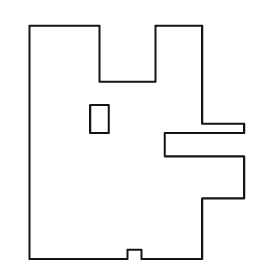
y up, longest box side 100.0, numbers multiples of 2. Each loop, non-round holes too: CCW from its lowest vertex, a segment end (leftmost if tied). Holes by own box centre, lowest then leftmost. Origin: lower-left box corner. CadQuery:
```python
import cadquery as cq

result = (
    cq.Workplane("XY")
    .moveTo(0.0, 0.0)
    .lineTo(42.0, 0.0)
    .lineTo(42.0, 4.0)
    .lineTo(48.0, 4.0)
    .lineTo(48.0, 0.0)
    .lineTo(74.0, 0.0)
    .lineTo(74.0, 26.0)
    .lineTo(92.0, 26.0)
    .lineTo(92.0, 44.0)
    .lineTo(58.0, 44.0)
    .lineTo(58.0, 54.0)
    .lineTo(92.0, 54.0)
    .lineTo(92.0, 58.0)
    .lineTo(74.0, 58.0)
    .lineTo(74.0, 100.0)
    .lineTo(54.0, 100.0)
    .lineTo(54.0, 76.0)
    .lineTo(30.0, 76.0)
    .lineTo(30.0, 100.0)
    .lineTo(0.0, 100.0)
    .close()
    .moveTo(26.0, 54.0)
    .lineTo(34.0, 54.0)
    .lineTo(34.0, 66.0)
    .lineTo(26.0, 66.0)
    .close()
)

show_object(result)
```